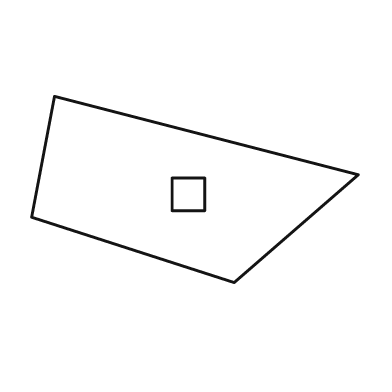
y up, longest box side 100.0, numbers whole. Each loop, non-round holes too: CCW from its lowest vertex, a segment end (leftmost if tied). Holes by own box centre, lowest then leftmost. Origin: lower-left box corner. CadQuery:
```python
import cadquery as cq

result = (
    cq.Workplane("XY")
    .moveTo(62.0, 0.0)
    .lineTo(100.0, 33.0)
    .lineTo(7.0, 57.0)
    .lineTo(0.0, 20.0)
    .close()
    .moveTo(43.0, 22.0)
    .lineTo(53.0, 22.0)
    .lineTo(53.0, 32.0)
    .lineTo(43.0, 32.0)
    .close()
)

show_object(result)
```